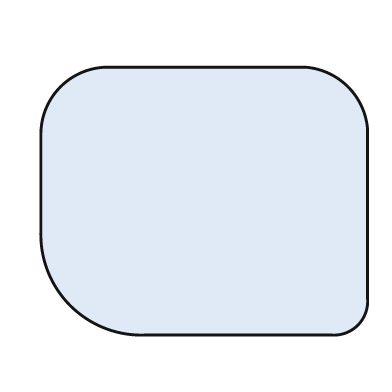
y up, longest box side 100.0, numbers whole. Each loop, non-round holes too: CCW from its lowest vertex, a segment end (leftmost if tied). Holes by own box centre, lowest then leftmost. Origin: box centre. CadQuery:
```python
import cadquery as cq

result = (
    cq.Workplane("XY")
    .moveTo(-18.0, -41.0)
    .lineTo(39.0, -41.0)
    .threePointArc((47.0, -38.0), (50.0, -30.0))
    .lineTo(50.0, 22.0)
    .threePointArc((44.0, 35.0), (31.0, 41.0))
    .lineTo(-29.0, 41.0)
    .threePointArc((-44.0, 35.0), (-50.0, 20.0))
    .lineTo(-50.0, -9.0)
    .threePointArc((-41.0, -32.0), (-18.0, -41.0))
    .close()
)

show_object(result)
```